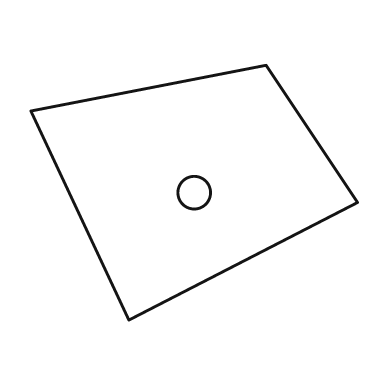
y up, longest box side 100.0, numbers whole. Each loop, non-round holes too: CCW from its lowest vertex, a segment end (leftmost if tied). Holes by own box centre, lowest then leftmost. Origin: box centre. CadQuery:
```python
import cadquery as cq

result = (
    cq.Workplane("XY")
    .moveTo(-20.0, -39.0)
    .lineTo(50.0, -3.0)
    .lineTo(22.0, 39.0)
    .lineTo(-50.0, 25.0)
    .close()
    .moveTo(0.0, 0.0)
    .circle(5.0)
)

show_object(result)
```